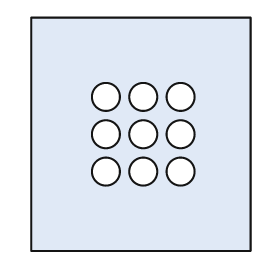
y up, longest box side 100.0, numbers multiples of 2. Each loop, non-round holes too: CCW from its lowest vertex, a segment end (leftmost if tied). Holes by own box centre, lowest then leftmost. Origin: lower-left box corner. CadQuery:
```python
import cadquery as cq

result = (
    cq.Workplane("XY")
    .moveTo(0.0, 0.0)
    .lineTo(94.0, 0.0)
    .lineTo(94.0, 100.0)
    .lineTo(0.0, 100.0)
    .close()
    .moveTo(32.0, 34.0)
    .circle(6.0)
    .moveTo(48.0, 34.0)
    .circle(6.0)
    .moveTo(64.0, 34.0)
    .circle(6.0)
    .moveTo(32.0, 50.0)
    .circle(6.0)
    .moveTo(48.0, 50.0)
    .circle(6.0)
    .moveTo(64.0, 50.0)
    .circle(6.0)
    .moveTo(32.0, 66.0)
    .circle(6.0)
    .moveTo(48.0, 66.0)
    .circle(6.0)
    .moveTo(64.0, 66.0)
    .circle(6.0)
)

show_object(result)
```